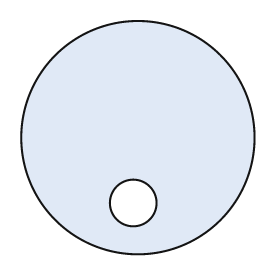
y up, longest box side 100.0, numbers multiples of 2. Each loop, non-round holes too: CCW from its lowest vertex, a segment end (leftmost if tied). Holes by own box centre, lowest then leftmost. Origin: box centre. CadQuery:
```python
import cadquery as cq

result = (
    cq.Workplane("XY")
    .moveTo(0.0, 0.0)
    .circle(50.0)
    .moveTo(-2.0, -28.0)
    .circle(10.0)
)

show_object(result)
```